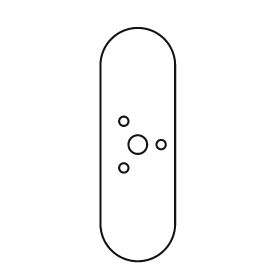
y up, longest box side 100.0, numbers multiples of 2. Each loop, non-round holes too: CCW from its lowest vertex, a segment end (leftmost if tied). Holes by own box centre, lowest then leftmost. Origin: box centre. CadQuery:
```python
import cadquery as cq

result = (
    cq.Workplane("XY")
    .moveTo(-16.0, -34.0)
    .threePointArc((0.0, -50.0), (16.0, -34.0))
    .lineTo(16.0, 34.0)
    .threePointArc((0.0, 50.0), (-16.0, 34.0))
    .close()
    .moveTo(-6.0, -10.0)
    .circle(2.0)
    .moveTo(0.0, 0.0)
    .circle(4.0)
    .moveTo(10.0, 0.0)
    .circle(2.0)
    .moveTo(-6.0, 10.0)
    .circle(2.0)
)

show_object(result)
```